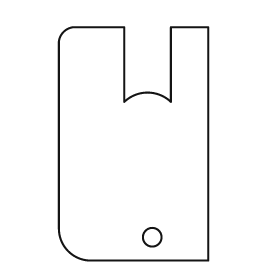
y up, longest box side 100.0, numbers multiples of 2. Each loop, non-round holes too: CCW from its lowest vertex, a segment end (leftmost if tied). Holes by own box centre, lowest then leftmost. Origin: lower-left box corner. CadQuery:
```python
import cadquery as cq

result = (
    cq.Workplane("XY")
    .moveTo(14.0, 0.0)
    .lineTo(64.0, 0.0)
    .lineTo(64.0, 100.0)
    .lineTo(48.0, 100.0)
    .lineTo(48.0, 68.0)
    .threePointArc((38.0, 72.0), (28.0, 68.0))
    .lineTo(28.0, 100.0)
    .lineTo(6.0, 100.0)
    .threePointArc((2.0, 98.0), (0.0, 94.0))
    .lineTo(0.0, 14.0)
    .threePointArc((4.0, 4.0), (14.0, 0.0))
    .close()
    .moveTo(40.0, 10.0)
    .circle(4.0)
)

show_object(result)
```